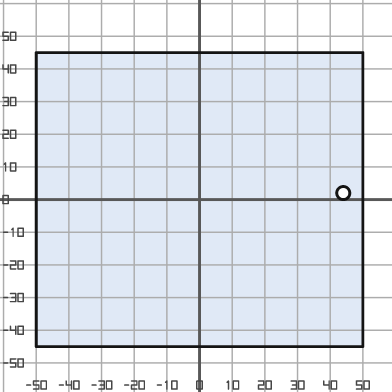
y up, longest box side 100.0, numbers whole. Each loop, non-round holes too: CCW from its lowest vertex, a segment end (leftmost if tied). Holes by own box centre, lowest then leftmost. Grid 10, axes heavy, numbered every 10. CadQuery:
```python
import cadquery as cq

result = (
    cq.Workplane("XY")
    .moveTo(-50.0, -45.0)
    .lineTo(50.0, -45.0)
    .lineTo(50.0, 45.0)
    .lineTo(-50.0, 45.0)
    .close()
    .moveTo(44.0, 2.0)
    .circle(2.0)
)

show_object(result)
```